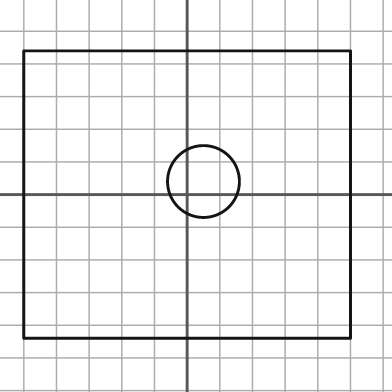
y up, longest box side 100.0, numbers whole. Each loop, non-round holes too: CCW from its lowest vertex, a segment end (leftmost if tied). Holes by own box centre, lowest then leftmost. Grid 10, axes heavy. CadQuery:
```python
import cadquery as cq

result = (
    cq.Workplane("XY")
    .moveTo(-50.0, -44.0)
    .lineTo(50.0, -44.0)
    .lineTo(50.0, 44.0)
    .lineTo(-50.0, 44.0)
    .close()
    .moveTo(5.0, 4.0)
    .circle(11.0)
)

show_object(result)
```